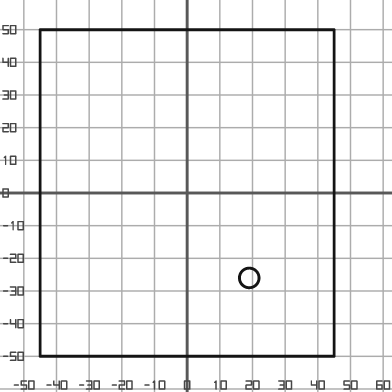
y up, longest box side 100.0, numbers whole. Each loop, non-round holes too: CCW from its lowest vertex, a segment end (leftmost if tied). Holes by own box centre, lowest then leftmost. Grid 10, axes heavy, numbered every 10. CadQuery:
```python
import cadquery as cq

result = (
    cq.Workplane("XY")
    .moveTo(-45.0, -50.0)
    .lineTo(45.0, -50.0)
    .lineTo(45.0, 50.0)
    .lineTo(-45.0, 50.0)
    .close()
    .moveTo(19.0, -26.0)
    .circle(3.0)
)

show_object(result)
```